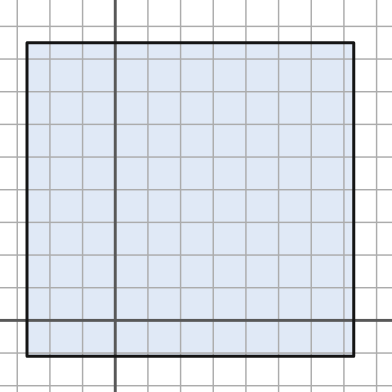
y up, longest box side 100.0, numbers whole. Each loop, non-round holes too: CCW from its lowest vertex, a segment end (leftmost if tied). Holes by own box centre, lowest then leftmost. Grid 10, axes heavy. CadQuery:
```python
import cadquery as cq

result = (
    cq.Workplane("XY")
    .moveTo(-27.0, -11.0)
    .lineTo(73.0, -11.0)
    .lineTo(73.0, 85.0)
    .lineTo(-27.0, 85.0)
    .close()
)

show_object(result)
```